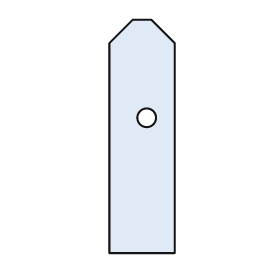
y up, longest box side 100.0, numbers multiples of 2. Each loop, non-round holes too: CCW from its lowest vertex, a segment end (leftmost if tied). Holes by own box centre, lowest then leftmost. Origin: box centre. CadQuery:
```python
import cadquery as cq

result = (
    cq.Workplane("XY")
    .moveTo(-14.0, -50.0)
    .lineTo(14.0, -50.0)
    .lineTo(14.0, 40.0)
    .lineTo(4.0, 50.0)
    .lineTo(-4.0, 50.0)
    .lineTo(-14.0, 40.0)
    .close()
    .moveTo(2.0, 8.0)
    .circle(4.0)
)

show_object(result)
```